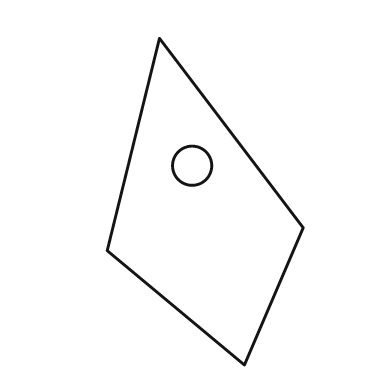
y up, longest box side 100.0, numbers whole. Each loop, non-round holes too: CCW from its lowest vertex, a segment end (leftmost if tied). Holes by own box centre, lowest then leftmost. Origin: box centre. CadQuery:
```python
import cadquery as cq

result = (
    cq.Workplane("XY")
    .moveTo(12.0, -50.0)
    .lineTo(30.0, -8.0)
    .lineTo(-14.0, 50.0)
    .lineTo(-30.0, -15.0)
    .close()
    .moveTo(-4.0, 11.0)
    .circle(6.0)
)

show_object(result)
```